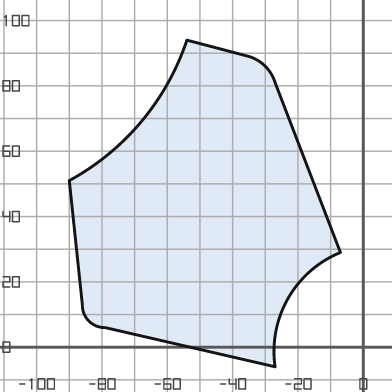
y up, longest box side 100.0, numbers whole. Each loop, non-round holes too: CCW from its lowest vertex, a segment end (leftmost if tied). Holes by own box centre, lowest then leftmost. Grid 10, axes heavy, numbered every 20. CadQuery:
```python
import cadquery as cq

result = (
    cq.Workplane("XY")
    .moveTo(-27.0, -6.0)
    .threePointArc((-23.0, 15.0), (-7.0, 29.0))
    .lineTo(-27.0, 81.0)
    .threePointArc((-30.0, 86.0), (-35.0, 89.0))
    .lineTo(-54.0, 94.0)
    .threePointArc((-68.0, 69.0), (-90.0, 51.0))
    .lineTo(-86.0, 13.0)
    .threePointArc((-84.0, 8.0), (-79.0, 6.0))
    .close()
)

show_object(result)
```